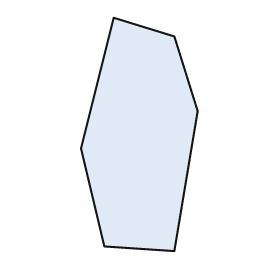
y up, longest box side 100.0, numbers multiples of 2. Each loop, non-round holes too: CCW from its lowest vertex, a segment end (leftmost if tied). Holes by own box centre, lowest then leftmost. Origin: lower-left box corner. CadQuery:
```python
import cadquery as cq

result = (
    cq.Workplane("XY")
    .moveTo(40.0, 0.0)
    .lineTo(50.0, 60.0)
    .lineTo(40.0, 92.0)
    .lineTo(14.0, 100.0)
    .lineTo(0.0, 44.0)
    .lineTo(10.0, 2.0)
    .close()
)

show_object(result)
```